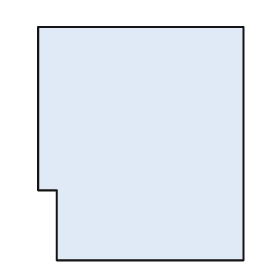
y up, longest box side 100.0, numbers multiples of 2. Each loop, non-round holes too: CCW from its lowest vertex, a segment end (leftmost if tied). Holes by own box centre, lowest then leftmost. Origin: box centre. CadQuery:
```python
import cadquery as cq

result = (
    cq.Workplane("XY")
    .moveTo(-36.0, -50.0)
    .lineTo(44.0, -50.0)
    .lineTo(44.0, 50.0)
    .lineTo(-44.0, 50.0)
    .lineTo(-44.0, -20.0)
    .lineTo(-36.0, -20.0)
    .close()
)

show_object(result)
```